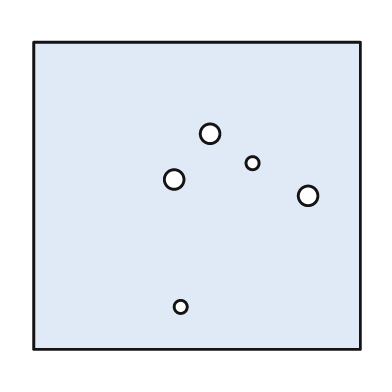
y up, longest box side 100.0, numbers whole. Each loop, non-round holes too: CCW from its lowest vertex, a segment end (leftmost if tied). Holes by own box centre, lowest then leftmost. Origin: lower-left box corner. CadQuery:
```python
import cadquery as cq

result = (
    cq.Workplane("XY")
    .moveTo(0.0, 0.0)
    .lineTo(100.0, 0.0)
    .lineTo(100.0, 94.0)
    .lineTo(0.0, 94.0)
    .close()
    .moveTo(45.0, 13.0)
    .circle(2.0)
    .moveTo(84.0, 47.0)
    .circle(3.0)
    .moveTo(43.0, 52.0)
    .circle(3.0)
    .moveTo(67.0, 57.0)
    .circle(2.0)
    .moveTo(54.0, 66.0)
    .circle(3.0)
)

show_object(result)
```